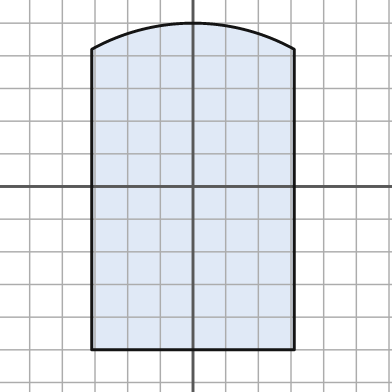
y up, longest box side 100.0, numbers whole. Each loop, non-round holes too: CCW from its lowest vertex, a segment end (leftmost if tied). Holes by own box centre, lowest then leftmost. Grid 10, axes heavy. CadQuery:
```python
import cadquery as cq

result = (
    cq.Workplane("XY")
    .moveTo(-31.0, -50.0)
    .lineTo(31.0, -50.0)
    .lineTo(31.0, 42.0)
    .threePointArc((0.0, 50.0), (-31.0, 42.0))
    .close()
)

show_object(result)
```